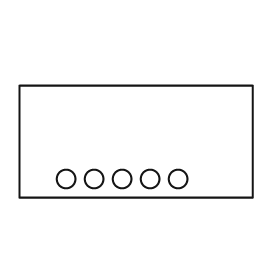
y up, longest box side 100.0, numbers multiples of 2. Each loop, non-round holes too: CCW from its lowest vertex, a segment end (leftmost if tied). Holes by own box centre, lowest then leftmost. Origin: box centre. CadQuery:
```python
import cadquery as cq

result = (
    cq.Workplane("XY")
    .moveTo(-50.0, -24.0)
    .lineTo(50.0, -24.0)
    .lineTo(50.0, 24.0)
    .lineTo(-50.0, 24.0)
    .close()
    .moveTo(-30.0, -16.0)
    .circle(4.0)
    .moveTo(-18.0, -16.0)
    .circle(4.0)
    .moveTo(-6.0, -16.0)
    .circle(4.0)
    .moveTo(6.0, -16.0)
    .circle(4.0)
    .moveTo(18.0, -16.0)
    .circle(4.0)
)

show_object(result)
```